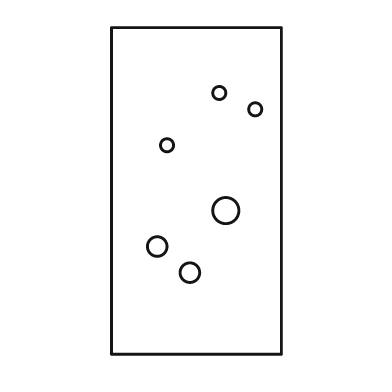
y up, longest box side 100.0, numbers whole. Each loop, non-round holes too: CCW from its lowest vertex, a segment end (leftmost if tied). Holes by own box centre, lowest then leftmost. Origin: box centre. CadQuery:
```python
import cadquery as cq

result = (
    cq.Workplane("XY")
    .moveTo(-26.0, -50.0)
    .lineTo(26.0, -50.0)
    .lineTo(26.0, 50.0)
    .lineTo(-26.0, 50.0)
    .close()
    .moveTo(-2.0, -25.0)
    .circle(3.0)
    .moveTo(-12.0, -17.0)
    .circle(3.0)
    .moveTo(9.0, -6.0)
    .circle(4.0)
    .moveTo(-9.0, 14.0)
    .circle(2.0)
    .moveTo(18.0, 25.0)
    .circle(2.0)
    .moveTo(7.0, 30.0)
    .circle(2.0)
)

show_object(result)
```